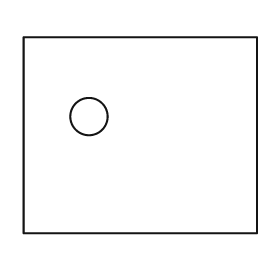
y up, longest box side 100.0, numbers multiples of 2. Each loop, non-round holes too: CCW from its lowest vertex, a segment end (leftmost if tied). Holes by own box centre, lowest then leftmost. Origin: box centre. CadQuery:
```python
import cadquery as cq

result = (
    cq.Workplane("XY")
    .moveTo(-50.0, -42.0)
    .lineTo(50.0, -42.0)
    .lineTo(50.0, 42.0)
    .lineTo(-50.0, 42.0)
    .close()
    .moveTo(-22.0, 8.0)
    .circle(8.0)
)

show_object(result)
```